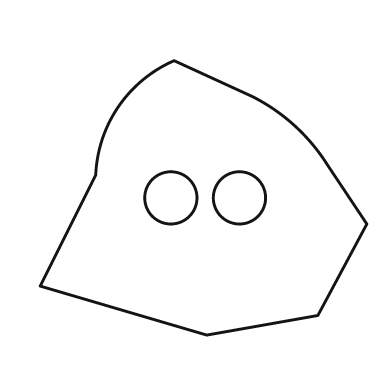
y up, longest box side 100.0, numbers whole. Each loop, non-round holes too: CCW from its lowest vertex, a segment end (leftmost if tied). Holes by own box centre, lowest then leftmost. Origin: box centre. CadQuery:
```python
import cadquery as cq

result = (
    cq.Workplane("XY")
    .moveTo(1.0, -42.0)
    .lineTo(35.0, -36.0)
    .lineTo(50.0, -8.0)
    .lineTo(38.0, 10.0)
    .threePointArc((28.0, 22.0), (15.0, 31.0))
    .lineTo(-9.0, 42.0)
    .threePointArc((-26.0, 28.0), (-33.0, 7.0))
    .lineTo(-50.0, -27.0)
    .close()
    .moveTo(-10.0, 0.0)
    .circle(8.0)
    .moveTo(11.0, 0.0)
    .circle(8.0)
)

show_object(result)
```